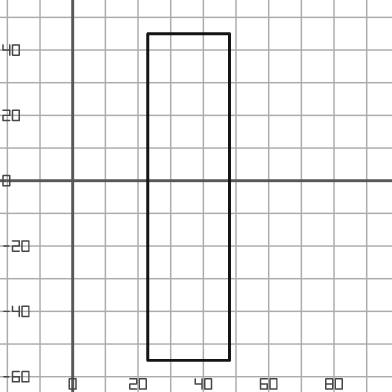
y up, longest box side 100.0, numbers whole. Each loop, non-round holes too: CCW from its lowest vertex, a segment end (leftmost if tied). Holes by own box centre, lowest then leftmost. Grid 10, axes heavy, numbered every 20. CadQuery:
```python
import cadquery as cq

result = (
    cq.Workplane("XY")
    .moveTo(23.0, -55.0)
    .lineTo(48.0, -55.0)
    .lineTo(48.0, 45.0)
    .lineTo(23.0, 45.0)
    .close()
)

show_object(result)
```